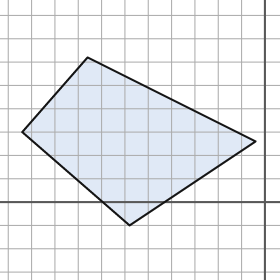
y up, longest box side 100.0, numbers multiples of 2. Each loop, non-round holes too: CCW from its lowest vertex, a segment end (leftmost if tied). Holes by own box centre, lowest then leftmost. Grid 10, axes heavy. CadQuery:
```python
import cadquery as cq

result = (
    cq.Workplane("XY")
    .moveTo(-58.0, -10.0)
    .lineTo(-4.0, 26.0)
    .lineTo(-76.0, 62.0)
    .lineTo(-104.0, 30.0)
    .close()
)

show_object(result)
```